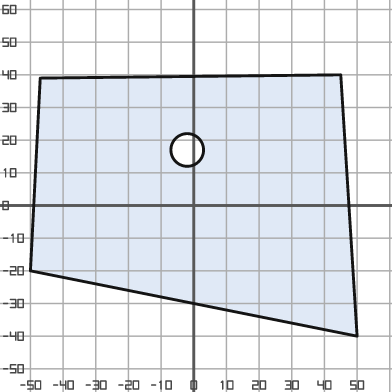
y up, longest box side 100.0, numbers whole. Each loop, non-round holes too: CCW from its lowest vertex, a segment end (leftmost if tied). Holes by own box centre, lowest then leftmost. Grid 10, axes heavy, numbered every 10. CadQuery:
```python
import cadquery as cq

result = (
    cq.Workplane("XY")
    .moveTo(50.0, -40.0)
    .lineTo(45.0, 40.0)
    .lineTo(-47.0, 39.0)
    .lineTo(-50.0, -20.0)
    .close()
    .moveTo(-2.0, 17.0)
    .circle(5.0)
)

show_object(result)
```